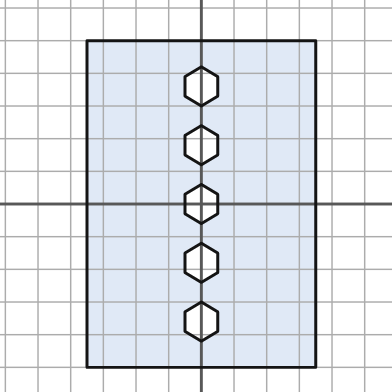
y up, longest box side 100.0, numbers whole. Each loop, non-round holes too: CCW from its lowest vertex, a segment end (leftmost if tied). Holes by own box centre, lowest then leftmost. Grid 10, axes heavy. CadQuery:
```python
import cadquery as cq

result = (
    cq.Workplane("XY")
    .moveTo(-35.0, -50.0)
    .lineTo(35.0, -50.0)
    .lineTo(35.0, 50.0)
    .lineTo(-35.0, 50.0)
    .close()
    .moveTo(0.0, -42.0)
    .lineTo(5.0, -39.0)
    .lineTo(5.0, -33.0)
    .lineTo(0.0, -30.0)
    .lineTo(-5.0, -33.0)
    .lineTo(-5.0, -39.0)
    .close()
    .moveTo(0.0, -24.0)
    .lineTo(5.0, -21.0)
    .lineTo(5.0, -15.0)
    .lineTo(0.0, -12.0)
    .lineTo(-5.0, -15.0)
    .lineTo(-5.0, -21.0)
    .close()
    .moveTo(0.0, -6.0)
    .lineTo(5.0, -3.0)
    .lineTo(5.0, 3.0)
    .lineTo(0.0, 6.0)
    .lineTo(-5.0, 3.0)
    .lineTo(-5.0, -3.0)
    .close()
    .moveTo(0.0, 12.0)
    .lineTo(5.0, 15.0)
    .lineTo(5.0, 21.0)
    .lineTo(0.0, 24.0)
    .lineTo(-5.0, 21.0)
    .lineTo(-5.0, 15.0)
    .close()
    .moveTo(0.0, 30.0)
    .lineTo(5.0, 33.0)
    .lineTo(5.0, 39.0)
    .lineTo(0.0, 42.0)
    .lineTo(-5.0, 39.0)
    .lineTo(-5.0, 33.0)
    .close()
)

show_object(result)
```